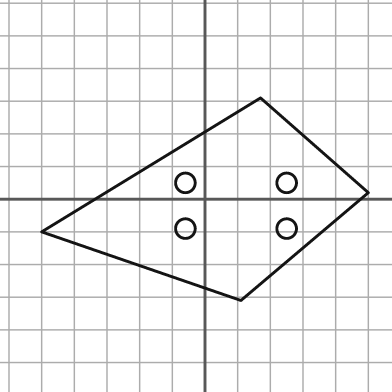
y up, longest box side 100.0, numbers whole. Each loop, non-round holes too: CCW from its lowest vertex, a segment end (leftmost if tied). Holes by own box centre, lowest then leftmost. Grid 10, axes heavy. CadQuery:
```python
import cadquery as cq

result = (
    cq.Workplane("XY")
    .moveTo(11.0, -31.0)
    .lineTo(50.0, 2.0)
    .lineTo(17.0, 31.0)
    .lineTo(-50.0, -10.0)
    .close()
    .moveTo(-6.0, -9.0)
    .circle(3.0)
    .moveTo(25.0, -9.0)
    .circle(3.0)
    .moveTo(-6.0, 5.0)
    .circle(3.0)
    .moveTo(25.0, 5.0)
    .circle(3.0)
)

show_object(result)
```